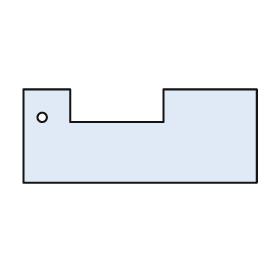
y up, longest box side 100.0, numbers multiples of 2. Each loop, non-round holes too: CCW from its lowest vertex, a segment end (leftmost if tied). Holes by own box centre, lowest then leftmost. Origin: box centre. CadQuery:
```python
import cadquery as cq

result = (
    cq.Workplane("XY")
    .moveTo(-50.0, -20.0)
    .lineTo(50.0, -20.0)
    .lineTo(50.0, 20.0)
    .lineTo(10.0, 20.0)
    .lineTo(10.0, 6.0)
    .lineTo(-30.0, 6.0)
    .lineTo(-30.0, 20.0)
    .lineTo(-50.0, 20.0)
    .close()
    .moveTo(-42.0, 8.0)
    .circle(2.0)
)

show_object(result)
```